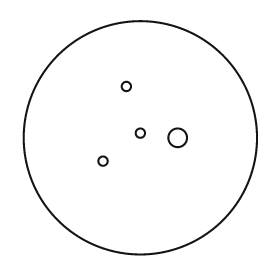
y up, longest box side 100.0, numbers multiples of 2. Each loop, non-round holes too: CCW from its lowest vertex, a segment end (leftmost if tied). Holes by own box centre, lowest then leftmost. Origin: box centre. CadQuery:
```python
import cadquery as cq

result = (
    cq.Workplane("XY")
    .moveTo(0.0, 0.0)
    .circle(50.0)
    .moveTo(-16.0, -10.0)
    .circle(2.0)
    .moveTo(16.0, 0.0)
    .circle(4.0)
    .moveTo(0.0, 2.0)
    .circle(2.0)
    .moveTo(-6.0, 22.0)
    .circle(2.0)
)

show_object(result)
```